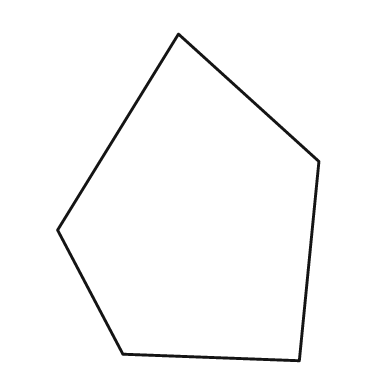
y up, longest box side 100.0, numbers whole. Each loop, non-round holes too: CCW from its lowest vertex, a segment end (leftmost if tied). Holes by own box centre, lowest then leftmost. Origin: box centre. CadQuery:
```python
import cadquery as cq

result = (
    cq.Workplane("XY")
    .moveTo(34.0, -50.0)
    .lineTo(40.0, 11.0)
    .lineTo(-3.0, 50.0)
    .lineTo(-40.0, -10.0)
    .lineTo(-20.0, -48.0)
    .close()
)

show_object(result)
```